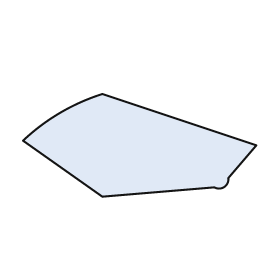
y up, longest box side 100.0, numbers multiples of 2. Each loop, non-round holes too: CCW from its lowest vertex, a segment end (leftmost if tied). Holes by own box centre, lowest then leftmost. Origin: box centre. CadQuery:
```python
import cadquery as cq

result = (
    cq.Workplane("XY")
    .moveTo(-16.0, -22.0)
    .lineTo(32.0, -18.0)
    .threePointArc((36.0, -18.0), (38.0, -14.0))
    .lineTo(50.0, 0.0)
    .lineTo(-16.0, 22.0)
    .threePointArc((-34.0, 14.0), (-50.0, 2.0))
    .close()
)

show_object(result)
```